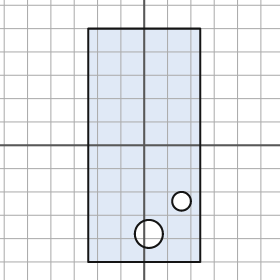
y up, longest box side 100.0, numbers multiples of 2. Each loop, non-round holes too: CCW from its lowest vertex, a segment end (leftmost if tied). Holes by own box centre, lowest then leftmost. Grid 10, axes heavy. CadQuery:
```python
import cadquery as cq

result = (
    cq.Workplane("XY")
    .moveTo(-24.0, -50.0)
    .lineTo(24.0, -50.0)
    .lineTo(24.0, 50.0)
    .lineTo(-24.0, 50.0)
    .close()
    .moveTo(2.0, -38.0)
    .circle(6.0)
    .moveTo(16.0, -24.0)
    .circle(4.0)
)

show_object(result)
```